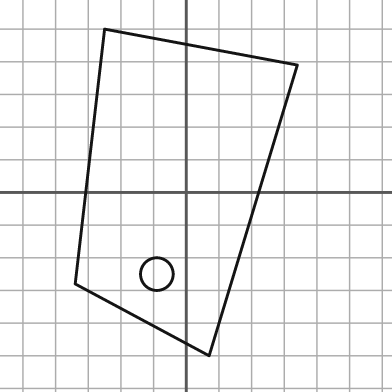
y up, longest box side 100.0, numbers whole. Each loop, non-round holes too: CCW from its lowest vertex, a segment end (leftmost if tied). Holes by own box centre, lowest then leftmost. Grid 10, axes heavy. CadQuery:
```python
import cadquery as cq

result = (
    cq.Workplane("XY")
    .moveTo(7.0, -50.0)
    .lineTo(34.0, 39.0)
    .lineTo(-25.0, 50.0)
    .lineTo(-34.0, -28.0)
    .close()
    .moveTo(-9.0, -25.0)
    .circle(5.0)
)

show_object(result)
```